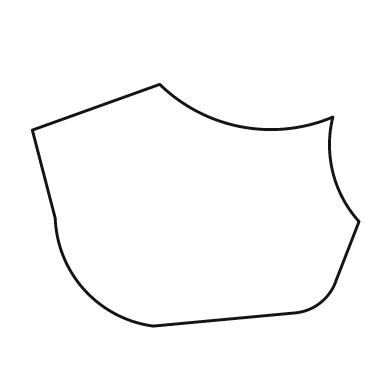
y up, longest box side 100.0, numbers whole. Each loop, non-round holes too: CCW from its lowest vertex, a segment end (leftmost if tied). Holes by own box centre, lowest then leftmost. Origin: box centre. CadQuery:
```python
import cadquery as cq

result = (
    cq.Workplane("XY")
    .moveTo(-13.0, -37.0)
    .lineTo(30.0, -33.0)
    .threePointArc((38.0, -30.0), (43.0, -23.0))
    .lineTo(50.0, -5.0)
    .threePointArc((42.0, 10.0), (42.0, 27.0))
    .threePointArc((14.0, 24.0), (-11.0, 37.0))
    .lineTo(-50.0, 23.0)
    .lineTo(-43.0, -4.0)
    .threePointArc((-34.0, -26.0), (-13.0, -37.0))
    .close()
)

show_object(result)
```